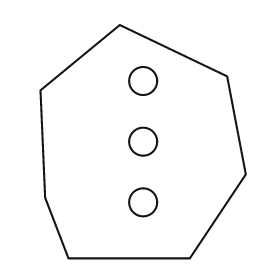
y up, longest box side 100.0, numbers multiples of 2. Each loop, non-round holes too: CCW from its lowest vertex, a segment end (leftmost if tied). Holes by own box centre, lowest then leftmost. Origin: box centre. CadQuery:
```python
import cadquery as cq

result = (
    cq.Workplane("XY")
    .moveTo(-32.0, -50.0)
    .lineTo(20.0, -50.0)
    .lineTo(44.0, -14.0)
    .lineTo(36.0, 28.0)
    .lineTo(-10.0, 50.0)
    .lineTo(-44.0, 22.0)
    .lineTo(-42.0, -24.0)
    .close()
    .moveTo(0.0, -26.0)
    .circle(6.0)
    .moveTo(0.0, 0.0)
    .circle(6.0)
    .moveTo(0.0, 26.0)
    .circle(6.0)
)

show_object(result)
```